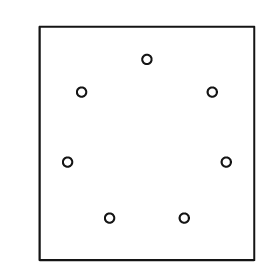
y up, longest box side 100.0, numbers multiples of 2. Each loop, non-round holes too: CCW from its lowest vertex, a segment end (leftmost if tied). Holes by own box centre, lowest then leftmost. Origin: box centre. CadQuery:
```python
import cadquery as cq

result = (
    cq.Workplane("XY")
    .moveTo(-46.0, -50.0)
    .lineTo(46.0, -50.0)
    .lineTo(46.0, 50.0)
    .lineTo(-46.0, 50.0)
    .close()
    .moveTo(-16.0, -32.0)
    .circle(2.0)
    .moveTo(16.0, -32.0)
    .circle(2.0)
    .moveTo(-34.0, -8.0)
    .circle(2.0)
    .moveTo(34.0, -8.0)
    .circle(2.0)
    .moveTo(-28.0, 22.0)
    .circle(2.0)
    .moveTo(28.0, 22.0)
    .circle(2.0)
    .moveTo(0.0, 36.0)
    .circle(2.0)
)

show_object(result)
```